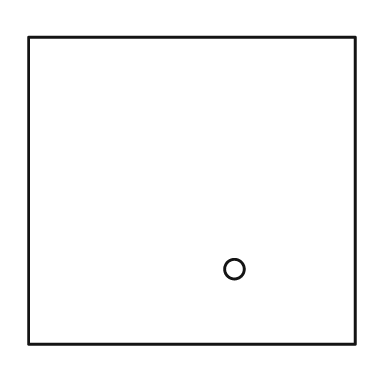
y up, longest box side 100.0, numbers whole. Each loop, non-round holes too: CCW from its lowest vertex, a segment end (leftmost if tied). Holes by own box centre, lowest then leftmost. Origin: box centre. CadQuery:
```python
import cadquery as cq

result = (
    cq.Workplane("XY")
    .moveTo(-50.0, -47.0)
    .lineTo(50.0, -47.0)
    .lineTo(50.0, 47.0)
    .lineTo(-50.0, 47.0)
    .close()
    .moveTo(13.0, -24.0)
    .circle(3.0)
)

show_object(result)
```